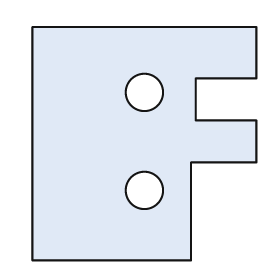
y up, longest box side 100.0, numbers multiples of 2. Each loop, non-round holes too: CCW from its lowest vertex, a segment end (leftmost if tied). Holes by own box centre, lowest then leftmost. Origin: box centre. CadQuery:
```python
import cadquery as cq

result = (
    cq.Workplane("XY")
    .moveTo(-48.0, -50.0)
    .lineTo(20.0, -50.0)
    .lineTo(20.0, -8.0)
    .lineTo(48.0, -8.0)
    .lineTo(48.0, 10.0)
    .lineTo(22.0, 10.0)
    .lineTo(22.0, 28.0)
    .lineTo(48.0, 28.0)
    .lineTo(48.0, 50.0)
    .lineTo(-48.0, 50.0)
    .close()
    .moveTo(0.0, -20.0)
    .circle(8.0)
    .moveTo(0.0, 22.0)
    .circle(8.0)
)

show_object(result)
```